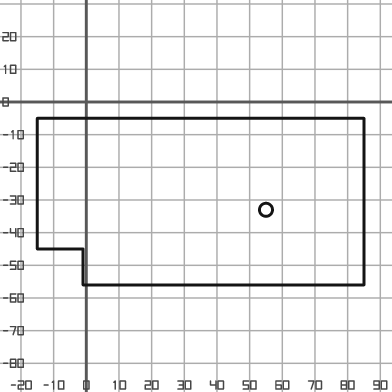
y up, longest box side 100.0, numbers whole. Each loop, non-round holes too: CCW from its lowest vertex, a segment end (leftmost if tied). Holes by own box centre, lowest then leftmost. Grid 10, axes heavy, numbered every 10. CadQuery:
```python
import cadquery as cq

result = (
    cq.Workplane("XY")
    .moveTo(-1.0, -56.0)
    .lineTo(85.0, -56.0)
    .lineTo(85.0, -5.0)
    .lineTo(-15.0, -5.0)
    .lineTo(-15.0, -45.0)
    .lineTo(-1.0, -45.0)
    .close()
    .moveTo(55.0, -33.0)
    .circle(2.0)
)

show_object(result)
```